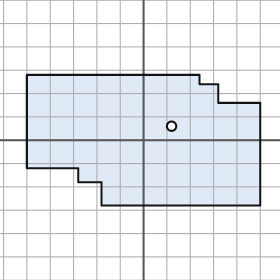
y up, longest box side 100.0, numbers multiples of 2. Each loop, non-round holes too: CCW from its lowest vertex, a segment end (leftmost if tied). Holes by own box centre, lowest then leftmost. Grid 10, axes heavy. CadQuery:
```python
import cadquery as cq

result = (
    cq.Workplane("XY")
    .moveTo(-18.0, -28.0)
    .lineTo(50.0, -28.0)
    .lineTo(50.0, 16.0)
    .lineTo(32.0, 16.0)
    .lineTo(32.0, 24.0)
    .lineTo(24.0, 24.0)
    .lineTo(24.0, 28.0)
    .lineTo(-50.0, 28.0)
    .lineTo(-50.0, -12.0)
    .lineTo(-28.0, -12.0)
    .lineTo(-28.0, -18.0)
    .lineTo(-18.0, -18.0)
    .close()
    .moveTo(12.0, 6.0)
    .circle(2.0)
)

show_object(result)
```